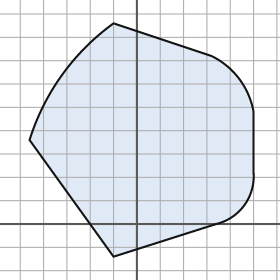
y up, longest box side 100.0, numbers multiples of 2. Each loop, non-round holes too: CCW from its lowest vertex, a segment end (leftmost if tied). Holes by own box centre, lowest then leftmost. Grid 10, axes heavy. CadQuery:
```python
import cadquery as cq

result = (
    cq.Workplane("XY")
    .moveTo(-10.0, -14.0)
    .lineTo(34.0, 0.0)
    .threePointArc((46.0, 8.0), (50.0, 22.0))
    .lineTo(50.0, 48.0)
    .threePointArc((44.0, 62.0), (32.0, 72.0))
    .lineTo(-10.0, 86.0)
    .threePointArc((-32.0, 64.0), (-46.0, 36.0))
    .close()
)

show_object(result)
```